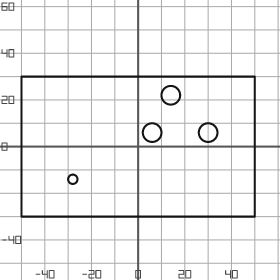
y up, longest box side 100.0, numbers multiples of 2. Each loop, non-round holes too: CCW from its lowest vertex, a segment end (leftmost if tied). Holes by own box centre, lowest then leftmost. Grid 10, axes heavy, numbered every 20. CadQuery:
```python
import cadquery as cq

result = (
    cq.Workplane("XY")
    .moveTo(-50.0, -30.0)
    .lineTo(50.0, -30.0)
    .lineTo(50.0, 30.0)
    .lineTo(-50.0, 30.0)
    .close()
    .moveTo(-28.0, -14.0)
    .circle(2.0)
    .moveTo(6.0, 6.0)
    .circle(4.0)
    .moveTo(30.0, 6.0)
    .circle(4.0)
    .moveTo(14.0, 22.0)
    .circle(4.0)
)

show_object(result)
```